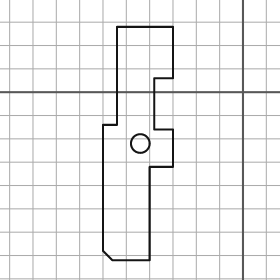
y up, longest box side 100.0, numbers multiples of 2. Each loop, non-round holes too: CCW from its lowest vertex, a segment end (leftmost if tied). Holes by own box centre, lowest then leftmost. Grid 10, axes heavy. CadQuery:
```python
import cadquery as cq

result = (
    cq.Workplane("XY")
    .moveTo(-56.0, -72.0)
    .lineTo(-40.0, -72.0)
    .lineTo(-40.0, -32.0)
    .lineTo(-30.0, -32.0)
    .lineTo(-30.0, -16.0)
    .lineTo(-38.0, -16.0)
    .lineTo(-38.0, 6.0)
    .lineTo(-30.0, 6.0)
    .lineTo(-30.0, 28.0)
    .lineTo(-54.0, 28.0)
    .lineTo(-54.0, -14.0)
    .lineTo(-60.0, -14.0)
    .lineTo(-60.0, -68.0)
    .close()
    .moveTo(-44.0, -22.0)
    .circle(4.0)
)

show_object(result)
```